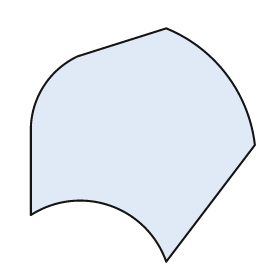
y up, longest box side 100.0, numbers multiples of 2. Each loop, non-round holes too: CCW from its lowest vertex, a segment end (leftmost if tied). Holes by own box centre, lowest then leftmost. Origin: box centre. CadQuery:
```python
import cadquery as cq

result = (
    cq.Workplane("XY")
    .moveTo(10.0, -50.0)
    .lineTo(48.0, 0.0)
    .threePointArc((36.0, 30.0), (10.0, 50.0))
    .lineTo(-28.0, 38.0)
    .threePointArc((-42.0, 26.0), (-48.0, 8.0))
    .lineTo(-48.0, -30.0)
    .threePointArc((-14.0, -26.0), (10.0, -50.0))
    .close()
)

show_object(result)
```